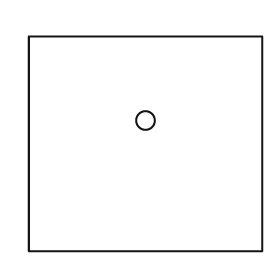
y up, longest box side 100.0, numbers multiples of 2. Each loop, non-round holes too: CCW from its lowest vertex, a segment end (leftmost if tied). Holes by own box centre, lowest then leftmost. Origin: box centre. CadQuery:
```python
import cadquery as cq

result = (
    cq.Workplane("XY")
    .moveTo(-50.0, -46.0)
    .lineTo(50.0, -46.0)
    .lineTo(50.0, 46.0)
    .lineTo(-50.0, 46.0)
    .close()
    .moveTo(0.0, 10.0)
    .circle(4.0)
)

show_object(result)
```